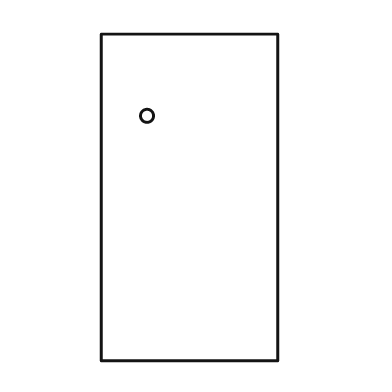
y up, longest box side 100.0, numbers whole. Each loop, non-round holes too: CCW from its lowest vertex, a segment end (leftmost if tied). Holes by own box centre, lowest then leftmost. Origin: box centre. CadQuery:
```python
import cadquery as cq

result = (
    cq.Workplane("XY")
    .moveTo(-27.0, -50.0)
    .lineTo(27.0, -50.0)
    .lineTo(27.0, 50.0)
    .lineTo(-27.0, 50.0)
    .close()
    .moveTo(-13.0, 25.0)
    .circle(2.0)
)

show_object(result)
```